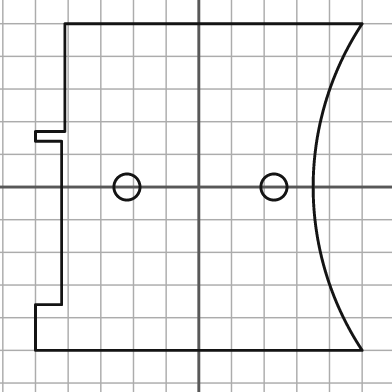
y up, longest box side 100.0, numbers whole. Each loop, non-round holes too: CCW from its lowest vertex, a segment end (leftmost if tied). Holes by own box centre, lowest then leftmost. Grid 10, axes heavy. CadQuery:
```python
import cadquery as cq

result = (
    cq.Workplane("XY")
    .moveTo(-50.0, -50.0)
    .lineTo(50.0, -50.0)
    .threePointArc((35.0, 0.0), (50.0, 50.0))
    .lineTo(-41.0, 50.0)
    .lineTo(-41.0, 17.0)
    .lineTo(-50.0, 17.0)
    .lineTo(-50.0, 14.0)
    .lineTo(-42.0, 14.0)
    .lineTo(-42.0, -36.0)
    .lineTo(-50.0, -36.0)
    .close()
    .moveTo(-22.0, 0.0)
    .circle(4.0)
    .moveTo(23.0, 0.0)
    .circle(4.0)
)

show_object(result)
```